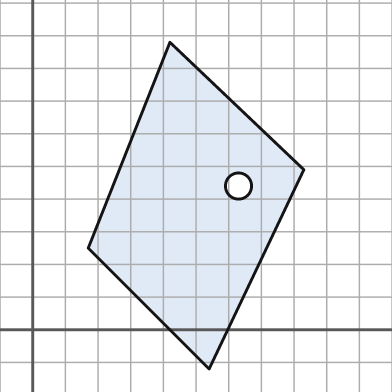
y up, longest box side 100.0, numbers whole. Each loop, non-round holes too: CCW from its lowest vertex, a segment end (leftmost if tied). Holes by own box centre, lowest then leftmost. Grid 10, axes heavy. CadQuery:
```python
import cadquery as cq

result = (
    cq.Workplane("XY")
    .moveTo(54.0, -12.0)
    .lineTo(83.0, 49.0)
    .lineTo(42.0, 88.0)
    .lineTo(17.0, 25.0)
    .close()
    .moveTo(63.0, 44.0)
    .circle(4.0)
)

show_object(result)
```